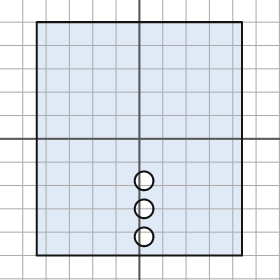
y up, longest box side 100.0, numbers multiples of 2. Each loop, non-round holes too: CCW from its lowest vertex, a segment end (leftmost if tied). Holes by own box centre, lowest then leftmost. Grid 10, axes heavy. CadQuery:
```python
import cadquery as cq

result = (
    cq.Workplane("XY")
    .moveTo(-44.0, -50.0)
    .lineTo(44.0, -50.0)
    .lineTo(44.0, 50.0)
    .lineTo(-44.0, 50.0)
    .close()
    .moveTo(2.0, -42.0)
    .circle(4.0)
    .moveTo(2.0, -30.0)
    .circle(4.0)
    .moveTo(2.0, -18.0)
    .circle(4.0)
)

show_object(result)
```